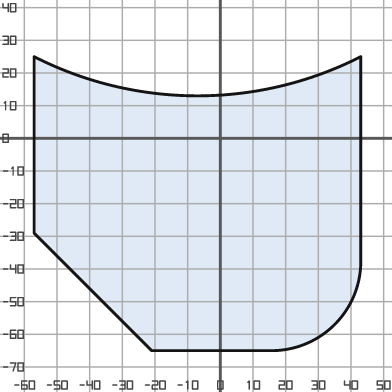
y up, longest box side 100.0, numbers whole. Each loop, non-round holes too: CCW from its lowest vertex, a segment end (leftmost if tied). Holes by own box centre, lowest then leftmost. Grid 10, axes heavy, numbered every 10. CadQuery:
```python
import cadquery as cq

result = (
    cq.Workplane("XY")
    .moveTo(-21.0, -65.0)
    .lineTo(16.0, -65.0)
    .threePointArc((35.0, -57.0), (43.0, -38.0))
    .lineTo(43.0, 25.0)
    .threePointArc((-7.0, 13.0), (-57.0, 25.0))
    .lineTo(-57.0, -29.0)
    .close()
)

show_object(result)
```